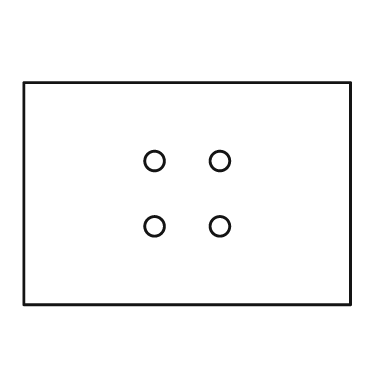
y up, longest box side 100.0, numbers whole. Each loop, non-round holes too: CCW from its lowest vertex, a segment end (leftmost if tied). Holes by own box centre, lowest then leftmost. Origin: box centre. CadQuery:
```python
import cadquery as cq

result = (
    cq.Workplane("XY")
    .moveTo(-50.0, -34.0)
    .lineTo(50.0, -34.0)
    .lineTo(50.0, 34.0)
    .lineTo(-50.0, 34.0)
    .close()
    .moveTo(-10.0, -10.0)
    .circle(3.0)
    .moveTo(10.0, -10.0)
    .circle(3.0)
    .moveTo(-10.0, 10.0)
    .circle(3.0)
    .moveTo(10.0, 10.0)
    .circle(3.0)
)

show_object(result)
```